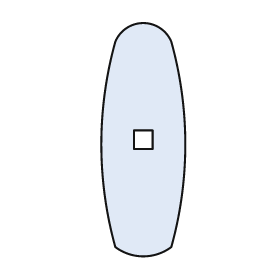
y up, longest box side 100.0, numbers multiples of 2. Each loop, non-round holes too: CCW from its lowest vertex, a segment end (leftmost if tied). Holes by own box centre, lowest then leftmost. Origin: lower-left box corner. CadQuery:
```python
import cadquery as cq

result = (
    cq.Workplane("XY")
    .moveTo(6.0, 4.0)
    .threePointArc((18.0, 0.0), (30.0, 4.0))
    .threePointArc((36.0, 48.0), (30.0, 92.0))
    .threePointArc((18.0, 100.0), (6.0, 92.0))
    .threePointArc((0.0, 48.0), (6.0, 4.0))
    .close()
    .moveTo(14.0, 46.0)
    .lineTo(22.0, 46.0)
    .lineTo(22.0, 54.0)
    .lineTo(14.0, 54.0)
    .close()
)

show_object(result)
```